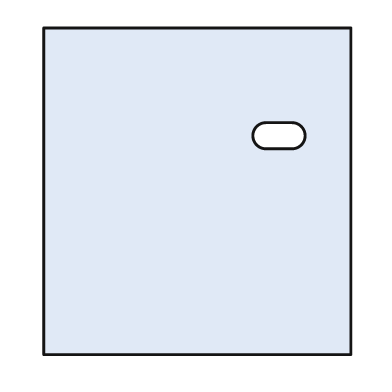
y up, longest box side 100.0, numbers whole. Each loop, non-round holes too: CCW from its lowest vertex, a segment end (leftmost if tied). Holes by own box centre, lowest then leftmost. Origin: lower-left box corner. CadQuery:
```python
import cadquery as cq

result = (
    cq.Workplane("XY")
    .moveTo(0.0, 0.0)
    .lineTo(94.0, 0.0)
    .lineTo(94.0, 100.0)
    .lineTo(0.0, 100.0)
    .close()
    .moveTo(68.0, 63.0)
    .lineTo(76.0, 63.0)
    .threePointArc((80.0, 67.0), (76.0, 71.0))
    .lineTo(68.0, 71.0)
    .threePointArc((64.0, 67.0), (68.0, 63.0))
    .close()
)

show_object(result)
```